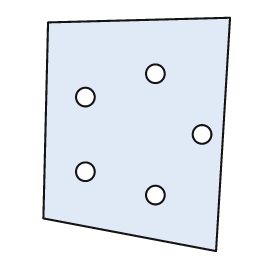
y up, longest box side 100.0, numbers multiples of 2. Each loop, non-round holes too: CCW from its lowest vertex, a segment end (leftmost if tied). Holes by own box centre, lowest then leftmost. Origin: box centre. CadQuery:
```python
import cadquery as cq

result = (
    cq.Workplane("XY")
    .moveTo(34.0, -50.0)
    .lineTo(40.0, 50.0)
    .lineTo(-38.0, 48.0)
    .lineTo(-40.0, -36.0)
    .close()
    .moveTo(8.0, -26.0)
    .circle(4.0)
    .moveTo(-22.0, -16.0)
    .circle(4.0)
    .moveTo(28.0, 0.0)
    .circle(4.0)
    .moveTo(-22.0, 16.0)
    .circle(4.0)
    .moveTo(8.0, 26.0)
    .circle(4.0)
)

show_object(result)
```